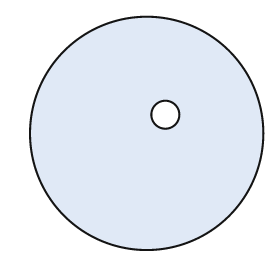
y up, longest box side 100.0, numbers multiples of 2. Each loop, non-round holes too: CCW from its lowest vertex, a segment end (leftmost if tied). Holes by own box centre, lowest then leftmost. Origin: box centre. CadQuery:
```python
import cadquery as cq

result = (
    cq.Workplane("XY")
    .moveTo(0.0, 0.0)
    .circle(50.0)
    .moveTo(8.0, 8.0)
    .circle(6.0)
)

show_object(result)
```